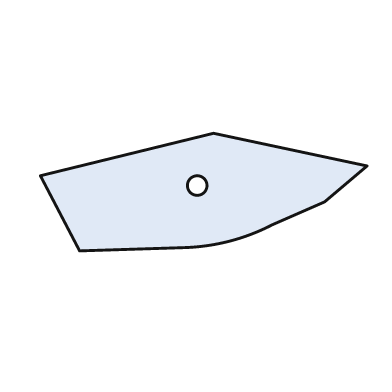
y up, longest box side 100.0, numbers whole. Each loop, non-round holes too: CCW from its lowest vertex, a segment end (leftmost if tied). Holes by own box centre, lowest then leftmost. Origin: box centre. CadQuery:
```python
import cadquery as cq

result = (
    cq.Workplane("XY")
    .moveTo(-38.0, -18.0)
    .lineTo(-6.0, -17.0)
    .threePointArc((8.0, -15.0), (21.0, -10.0))
    .lineTo(37.0, -3.0)
    .lineTo(50.0, 8.0)
    .lineTo(3.0, 18.0)
    .lineTo(-50.0, 5.0)
    .close()
    .moveTo(-2.0, 2.0)
    .circle(3.0)
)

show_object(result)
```